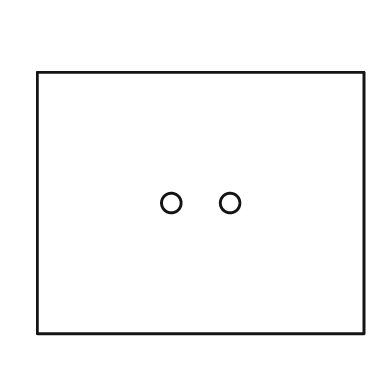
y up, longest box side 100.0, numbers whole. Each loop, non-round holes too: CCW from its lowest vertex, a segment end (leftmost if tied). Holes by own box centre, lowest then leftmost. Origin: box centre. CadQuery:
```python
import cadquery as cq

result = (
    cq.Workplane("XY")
    .moveTo(-50.0, -40.0)
    .lineTo(50.0, -40.0)
    .lineTo(50.0, 40.0)
    .lineTo(-50.0, 40.0)
    .close()
    .moveTo(-9.0, 0.0)
    .circle(3.0)
    .moveTo(9.0, 0.0)
    .circle(3.0)
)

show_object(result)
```